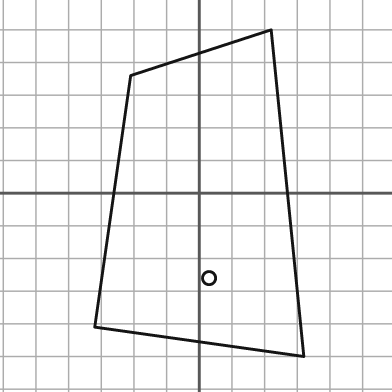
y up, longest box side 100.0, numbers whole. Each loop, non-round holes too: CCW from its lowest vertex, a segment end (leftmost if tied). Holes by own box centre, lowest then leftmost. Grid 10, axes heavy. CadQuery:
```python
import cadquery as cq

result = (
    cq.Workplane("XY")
    .moveTo(32.0, -50.0)
    .lineTo(22.0, 50.0)
    .lineTo(-21.0, 36.0)
    .lineTo(-32.0, -41.0)
    .close()
    .moveTo(3.0, -26.0)
    .circle(2.0)
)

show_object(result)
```